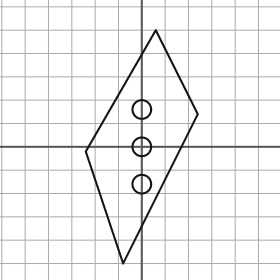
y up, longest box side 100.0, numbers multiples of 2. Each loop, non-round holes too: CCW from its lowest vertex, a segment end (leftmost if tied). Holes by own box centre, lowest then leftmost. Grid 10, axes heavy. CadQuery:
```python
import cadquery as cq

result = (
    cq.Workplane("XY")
    .moveTo(-8.0, -50.0)
    .lineTo(24.0, 14.0)
    .lineTo(6.0, 50.0)
    .lineTo(-24.0, -2.0)
    .close()
    .moveTo(0.0, -16.0)
    .circle(4.0)
    .moveTo(0.0, 0.0)
    .circle(4.0)
    .moveTo(0.0, 16.0)
    .circle(4.0)
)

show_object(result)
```